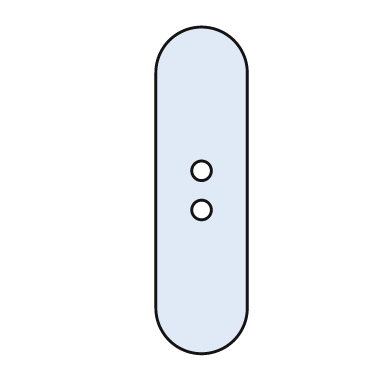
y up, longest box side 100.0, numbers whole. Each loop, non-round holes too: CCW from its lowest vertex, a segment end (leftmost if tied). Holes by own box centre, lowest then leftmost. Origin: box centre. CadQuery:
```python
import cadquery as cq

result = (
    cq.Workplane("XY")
    .moveTo(-14.0, -36.0)
    .threePointArc((0.0, -50.0), (14.0, -36.0))
    .lineTo(14.0, 36.0)
    .threePointArc((0.0, 50.0), (-14.0, 36.0))
    .close()
    .moveTo(0.0, -6.0)
    .circle(3.0)
    .moveTo(0.0, 6.0)
    .circle(3.0)
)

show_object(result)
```